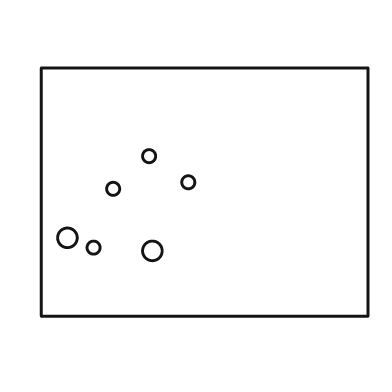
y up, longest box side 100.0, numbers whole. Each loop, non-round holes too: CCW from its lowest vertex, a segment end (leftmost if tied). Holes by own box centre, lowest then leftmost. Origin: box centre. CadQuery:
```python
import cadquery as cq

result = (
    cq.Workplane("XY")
    .moveTo(-50.0, -38.0)
    .lineTo(50.0, -38.0)
    .lineTo(50.0, 38.0)
    .lineTo(-50.0, 38.0)
    .close()
    .moveTo(-16.0, -18.0)
    .circle(3.0)
    .moveTo(-34.0, -17.0)
    .circle(2.0)
    .moveTo(-42.0, -14.0)
    .circle(3.0)
    .moveTo(-28.0, 1.0)
    .circle(2.0)
    .moveTo(-5.0, 3.0)
    .circle(2.0)
    .moveTo(-17.0, 11.0)
    .circle(2.0)
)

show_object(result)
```